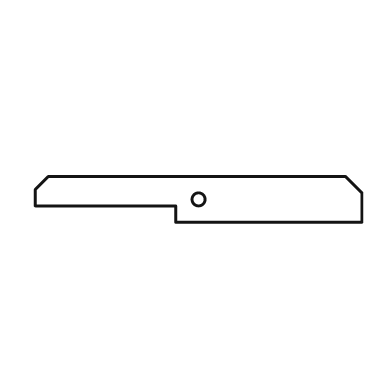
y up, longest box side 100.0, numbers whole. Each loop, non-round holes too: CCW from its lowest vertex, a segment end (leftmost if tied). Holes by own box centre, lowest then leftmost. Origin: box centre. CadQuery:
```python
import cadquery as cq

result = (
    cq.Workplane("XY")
    .moveTo(-7.0, -7.0)
    .lineTo(50.0, -7.0)
    .lineTo(50.0, 2.0)
    .lineTo(45.0, 7.0)
    .lineTo(-46.0, 7.0)
    .lineTo(-50.0, 3.0)
    .lineTo(-50.0, -2.0)
    .lineTo(-7.0, -2.0)
    .close()
    .moveTo(0.0, 0.0)
    .circle(2.0)
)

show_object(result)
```